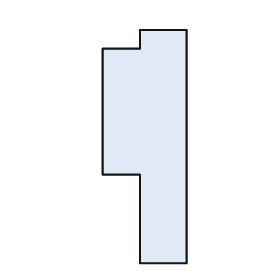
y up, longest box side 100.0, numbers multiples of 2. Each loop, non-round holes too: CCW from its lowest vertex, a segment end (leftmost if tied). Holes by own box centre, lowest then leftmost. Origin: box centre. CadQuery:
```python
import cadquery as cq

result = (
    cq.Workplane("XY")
    .moveTo(-2.0, -50.0)
    .lineTo(18.0, -50.0)
    .lineTo(18.0, 50.0)
    .lineTo(-2.0, 50.0)
    .lineTo(-2.0, 42.0)
    .lineTo(-18.0, 42.0)
    .lineTo(-18.0, -12.0)
    .lineTo(-2.0, -12.0)
    .close()
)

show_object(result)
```